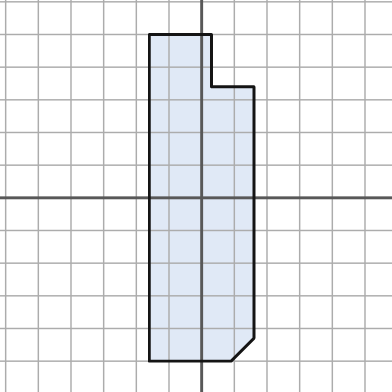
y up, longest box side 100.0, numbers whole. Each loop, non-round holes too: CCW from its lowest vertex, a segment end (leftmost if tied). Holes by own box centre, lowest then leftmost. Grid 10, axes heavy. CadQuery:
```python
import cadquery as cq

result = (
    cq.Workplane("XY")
    .moveTo(-16.0, -50.0)
    .lineTo(9.0, -50.0)
    .lineTo(16.0, -43.0)
    .lineTo(16.0, 34.0)
    .lineTo(3.0, 34.0)
    .lineTo(3.0, 50.0)
    .lineTo(-16.0, 50.0)
    .close()
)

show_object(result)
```